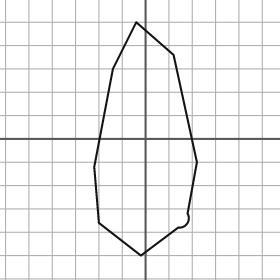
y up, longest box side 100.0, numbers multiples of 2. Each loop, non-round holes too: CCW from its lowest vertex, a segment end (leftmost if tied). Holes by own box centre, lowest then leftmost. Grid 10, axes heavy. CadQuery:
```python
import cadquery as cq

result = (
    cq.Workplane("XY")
    .moveTo(-2.0, -50.0)
    .lineTo(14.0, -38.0)
    .threePointArc((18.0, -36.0), (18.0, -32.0))
    .lineTo(22.0, -10.0)
    .lineTo(12.0, 36.0)
    .lineTo(-4.0, 50.0)
    .lineTo(-14.0, 30.0)
    .lineTo(-22.0, -12.0)
    .lineTo(-20.0, -36.0)
    .close()
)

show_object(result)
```